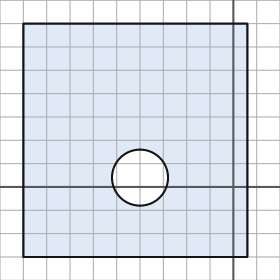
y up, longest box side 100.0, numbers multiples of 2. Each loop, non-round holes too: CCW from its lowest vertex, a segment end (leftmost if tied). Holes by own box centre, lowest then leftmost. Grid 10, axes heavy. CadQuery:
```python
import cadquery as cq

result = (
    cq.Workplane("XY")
    .moveTo(-90.0, -30.0)
    .lineTo(6.0, -30.0)
    .lineTo(6.0, 70.0)
    .lineTo(-90.0, 70.0)
    .close()
    .moveTo(-40.0, 4.0)
    .circle(12.0)
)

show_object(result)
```